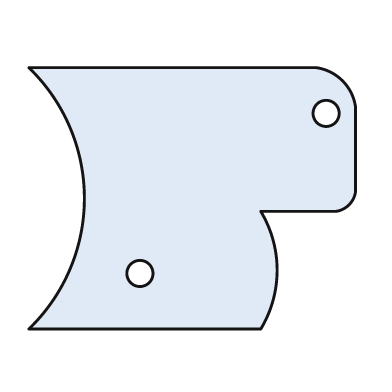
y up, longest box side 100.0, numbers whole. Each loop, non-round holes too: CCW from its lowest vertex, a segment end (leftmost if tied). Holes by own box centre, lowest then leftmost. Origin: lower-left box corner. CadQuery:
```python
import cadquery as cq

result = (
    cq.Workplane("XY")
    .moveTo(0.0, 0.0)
    .lineTo(71.0, 0.0)
    .threePointArc((76.0, 18.0), (71.0, 36.0))
    .lineTo(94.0, 36.0)
    .threePointArc((98.0, 38.0), (100.0, 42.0))
    .lineTo(100.0, 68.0)
    .threePointArc((96.0, 76.0), (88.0, 80.0))
    .lineTo(0.0, 80.0)
    .threePointArc((17.0, 40.0), (0.0, 0.0))
    .close()
    .moveTo(34.0, 17.0)
    .circle(4.0)
    .moveTo(91.0, 66.0)
    .circle(4.0)
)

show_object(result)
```